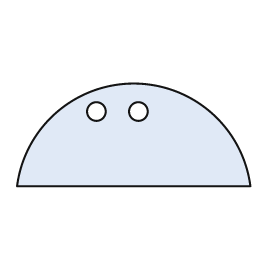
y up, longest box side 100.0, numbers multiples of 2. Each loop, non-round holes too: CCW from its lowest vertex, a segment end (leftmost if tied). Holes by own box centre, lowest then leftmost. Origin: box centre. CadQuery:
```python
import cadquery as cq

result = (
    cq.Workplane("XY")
    .moveTo(-50.0, -22.0)
    .lineTo(50.0, -22.0)
    .threePointArc((0.0, 22.0), (-50.0, -22.0))
    .close()
    .moveTo(-16.0, 10.0)
    .circle(4.0)
    .moveTo(2.0, 10.0)
    .circle(4.0)
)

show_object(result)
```